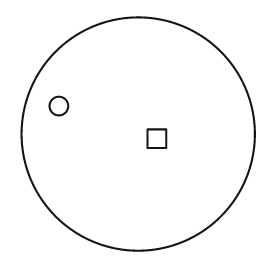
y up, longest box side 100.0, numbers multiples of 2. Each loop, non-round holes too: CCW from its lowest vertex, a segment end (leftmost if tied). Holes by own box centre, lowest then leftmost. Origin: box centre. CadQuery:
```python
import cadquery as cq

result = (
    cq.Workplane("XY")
    .moveTo(0.0, 0.0)
    .circle(50.0)
    .moveTo(4.0, -6.0)
    .lineTo(12.0, -6.0)
    .lineTo(12.0, 2.0)
    .lineTo(4.0, 2.0)
    .close()
    .moveTo(-34.0, 12.0)
    .circle(4.0)
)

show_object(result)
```